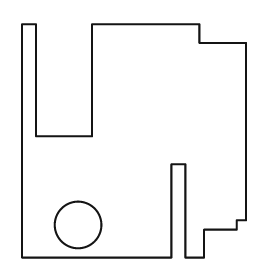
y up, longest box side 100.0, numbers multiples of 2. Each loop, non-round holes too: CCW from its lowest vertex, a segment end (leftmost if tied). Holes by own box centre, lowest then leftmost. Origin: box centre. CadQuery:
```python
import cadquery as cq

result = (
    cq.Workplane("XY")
    .moveTo(-48.0, -50.0)
    .lineTo(16.0, -50.0)
    .lineTo(16.0, -10.0)
    .lineTo(22.0, -10.0)
    .lineTo(22.0, -50.0)
    .lineTo(30.0, -50.0)
    .lineTo(30.0, -38.0)
    .lineTo(44.0, -38.0)
    .lineTo(44.0, -34.0)
    .lineTo(48.0, -34.0)
    .lineTo(48.0, 42.0)
    .lineTo(28.0, 42.0)
    .lineTo(28.0, 50.0)
    .lineTo(-18.0, 50.0)
    .lineTo(-18.0, 2.0)
    .lineTo(-42.0, 2.0)
    .lineTo(-42.0, 50.0)
    .lineTo(-48.0, 50.0)
    .close()
    .moveTo(-24.0, -36.0)
    .circle(10.0)
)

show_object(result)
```